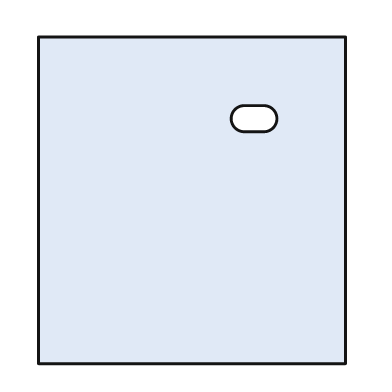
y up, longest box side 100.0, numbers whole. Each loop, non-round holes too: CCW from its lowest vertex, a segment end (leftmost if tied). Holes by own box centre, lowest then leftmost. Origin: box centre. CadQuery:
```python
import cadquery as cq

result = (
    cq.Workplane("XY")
    .moveTo(-47.0, -50.0)
    .lineTo(47.0, -50.0)
    .lineTo(47.0, 50.0)
    .lineTo(-47.0, 50.0)
    .close()
    .moveTo(16.0, 21.0)
    .lineTo(22.0, 21.0)
    .threePointArc((26.0, 25.0), (22.0, 29.0))
    .lineTo(16.0, 29.0)
    .threePointArc((12.0, 25.0), (16.0, 21.0))
    .close()
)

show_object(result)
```